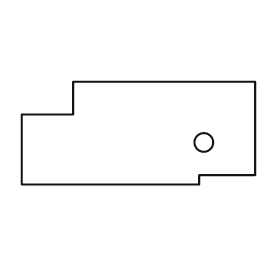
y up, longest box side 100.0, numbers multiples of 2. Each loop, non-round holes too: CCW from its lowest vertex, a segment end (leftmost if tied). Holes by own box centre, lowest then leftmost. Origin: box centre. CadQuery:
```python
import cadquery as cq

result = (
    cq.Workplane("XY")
    .moveTo(-50.0, -22.0)
    .lineTo(26.0, -22.0)
    .lineTo(26.0, -18.0)
    .lineTo(50.0, -18.0)
    .lineTo(50.0, 22.0)
    .lineTo(-28.0, 22.0)
    .lineTo(-28.0, 8.0)
    .lineTo(-50.0, 8.0)
    .close()
    .moveTo(28.0, -4.0)
    .circle(4.0)
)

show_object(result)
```